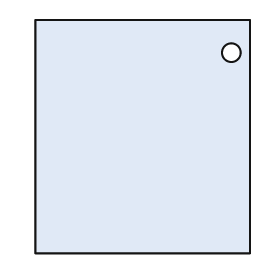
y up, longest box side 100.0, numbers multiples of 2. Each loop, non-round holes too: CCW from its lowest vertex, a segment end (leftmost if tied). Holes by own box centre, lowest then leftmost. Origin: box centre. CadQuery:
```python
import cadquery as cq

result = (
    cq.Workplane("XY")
    .moveTo(-46.0, -50.0)
    .lineTo(46.0, -50.0)
    .lineTo(46.0, 50.0)
    .lineTo(-46.0, 50.0)
    .close()
    .moveTo(38.0, 36.0)
    .circle(4.0)
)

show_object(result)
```